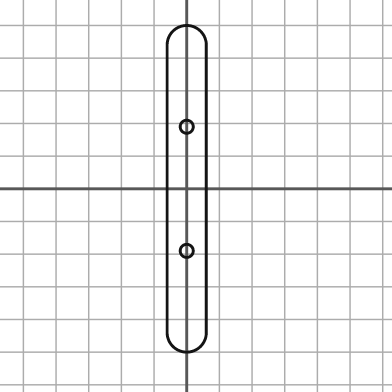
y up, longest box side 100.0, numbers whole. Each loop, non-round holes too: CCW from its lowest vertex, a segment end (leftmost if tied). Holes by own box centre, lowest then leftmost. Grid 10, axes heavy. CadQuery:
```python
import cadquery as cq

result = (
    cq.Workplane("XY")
    .moveTo(-6.0, -44.0)
    .threePointArc((0.0, -50.0), (6.0, -44.0))
    .lineTo(6.0, 44.0)
    .threePointArc((0.0, 50.0), (-6.0, 44.0))
    .close()
    .moveTo(0.0, -19.0)
    .circle(2.0)
    .moveTo(0.0, 19.0)
    .circle(2.0)
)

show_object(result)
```